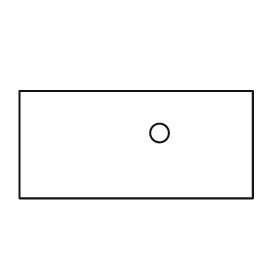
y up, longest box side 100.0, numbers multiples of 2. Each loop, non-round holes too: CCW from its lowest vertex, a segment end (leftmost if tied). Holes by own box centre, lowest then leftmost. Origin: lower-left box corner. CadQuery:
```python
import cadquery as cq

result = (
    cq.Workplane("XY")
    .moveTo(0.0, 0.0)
    .lineTo(100.0, 0.0)
    .lineTo(100.0, 46.0)
    .lineTo(0.0, 46.0)
    .close()
    .moveTo(60.0, 28.0)
    .circle(4.0)
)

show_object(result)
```